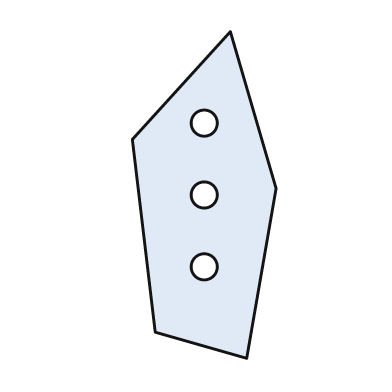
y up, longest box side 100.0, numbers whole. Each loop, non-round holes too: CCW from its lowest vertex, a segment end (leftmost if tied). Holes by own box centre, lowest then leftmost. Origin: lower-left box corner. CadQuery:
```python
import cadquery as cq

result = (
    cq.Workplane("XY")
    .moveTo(35.0, 0.0)
    .lineTo(44.0, 52.0)
    .lineTo(30.0, 100.0)
    .lineTo(0.0, 67.0)
    .lineTo(7.0, 8.0)
    .close()
    .moveTo(22.0, 28.0)
    .circle(4.0)
    .moveTo(22.0, 50.0)
    .circle(4.0)
    .moveTo(22.0, 72.0)
    .circle(4.0)
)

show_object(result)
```